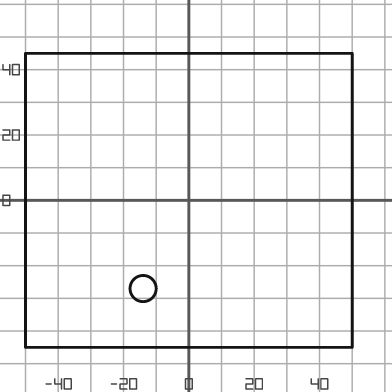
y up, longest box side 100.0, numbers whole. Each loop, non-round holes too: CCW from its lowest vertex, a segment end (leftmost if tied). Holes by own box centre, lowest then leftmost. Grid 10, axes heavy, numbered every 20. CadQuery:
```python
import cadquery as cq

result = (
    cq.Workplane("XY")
    .moveTo(-50.0, -45.0)
    .lineTo(50.0, -45.0)
    .lineTo(50.0, 45.0)
    .lineTo(-50.0, 45.0)
    .close()
    .moveTo(-14.0, -27.0)
    .circle(4.0)
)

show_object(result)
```